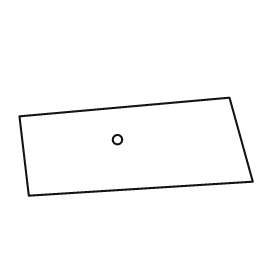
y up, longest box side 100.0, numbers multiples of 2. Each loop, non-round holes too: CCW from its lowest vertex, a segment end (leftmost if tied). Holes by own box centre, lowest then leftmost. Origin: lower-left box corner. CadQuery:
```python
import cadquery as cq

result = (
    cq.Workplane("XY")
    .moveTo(4.0, 0.0)
    .lineTo(100.0, 6.0)
    .lineTo(90.0, 42.0)
    .lineTo(0.0, 34.0)
    .close()
    .moveTo(42.0, 24.0)
    .circle(2.0)
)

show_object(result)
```